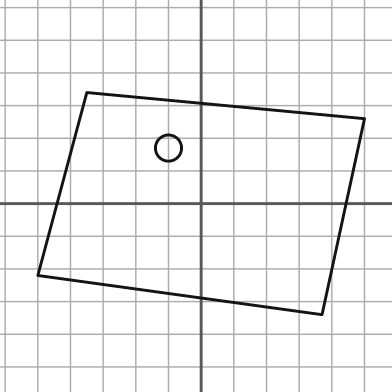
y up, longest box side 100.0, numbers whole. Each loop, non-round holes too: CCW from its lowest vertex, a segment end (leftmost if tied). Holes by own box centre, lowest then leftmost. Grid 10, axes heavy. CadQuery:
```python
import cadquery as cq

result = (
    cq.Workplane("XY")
    .moveTo(37.0, -34.0)
    .lineTo(50.0, 26.0)
    .lineTo(-35.0, 34.0)
    .lineTo(-50.0, -22.0)
    .close()
    .moveTo(-10.0, 17.0)
    .circle(4.0)
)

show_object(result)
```